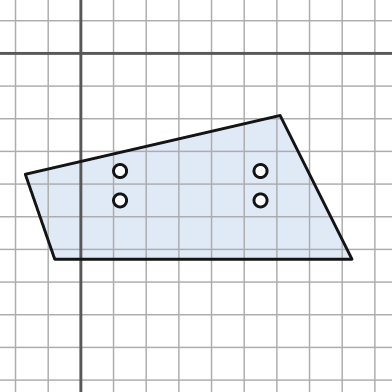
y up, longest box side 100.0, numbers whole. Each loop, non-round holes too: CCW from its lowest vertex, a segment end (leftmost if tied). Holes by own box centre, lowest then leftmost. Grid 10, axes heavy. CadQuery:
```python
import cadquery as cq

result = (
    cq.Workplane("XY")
    .moveTo(-8.0, -63.0)
    .lineTo(83.0, -63.0)
    .lineTo(61.0, -19.0)
    .lineTo(-17.0, -37.0)
    .close()
    .moveTo(12.0, -45.0)
    .circle(2.0)
    .moveTo(55.0, -45.0)
    .circle(2.0)
    .moveTo(12.0, -36.0)
    .circle(2.0)
    .moveTo(55.0, -36.0)
    .circle(2.0)
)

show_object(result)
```